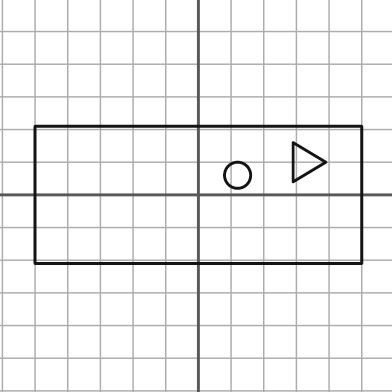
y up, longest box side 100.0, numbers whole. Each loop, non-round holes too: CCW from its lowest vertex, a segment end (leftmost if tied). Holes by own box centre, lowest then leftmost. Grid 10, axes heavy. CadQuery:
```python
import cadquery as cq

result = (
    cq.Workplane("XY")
    .moveTo(-50.0, -21.0)
    .lineTo(50.0, -21.0)
    .lineTo(50.0, 21.0)
    .lineTo(-50.0, 21.0)
    .close()
    .moveTo(12.0, 6.0)
    .circle(4.0)
    .moveTo(29.0, 4.0)
    .lineTo(39.0, 10.0)
    .lineTo(29.0, 16.0)
    .close()
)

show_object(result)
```